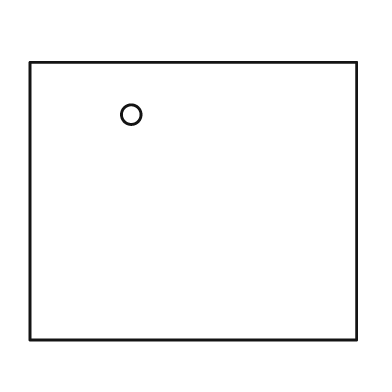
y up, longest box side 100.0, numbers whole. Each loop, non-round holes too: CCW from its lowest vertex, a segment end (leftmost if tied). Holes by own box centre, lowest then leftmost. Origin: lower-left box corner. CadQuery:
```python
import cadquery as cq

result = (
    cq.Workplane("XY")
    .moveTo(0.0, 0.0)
    .lineTo(100.0, 0.0)
    .lineTo(100.0, 85.0)
    .lineTo(0.0, 85.0)
    .close()
    .moveTo(31.0, 69.0)
    .circle(3.0)
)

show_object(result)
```